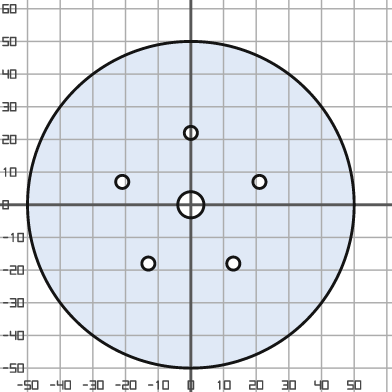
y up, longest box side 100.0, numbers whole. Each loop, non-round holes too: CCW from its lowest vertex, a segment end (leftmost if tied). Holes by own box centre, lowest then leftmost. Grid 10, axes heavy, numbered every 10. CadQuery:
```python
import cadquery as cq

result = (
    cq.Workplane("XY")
    .moveTo(0.0, 0.0)
    .circle(50.0)
    .moveTo(-13.0, -18.0)
    .circle(2.0)
    .moveTo(13.0, -18.0)
    .circle(2.0)
    .moveTo(0.0, 0.0)
    .circle(4.0)
    .moveTo(-21.0, 7.0)
    .circle(2.0)
    .moveTo(21.0, 7.0)
    .circle(2.0)
    .moveTo(0.0, 22.0)
    .circle(2.0)
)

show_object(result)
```